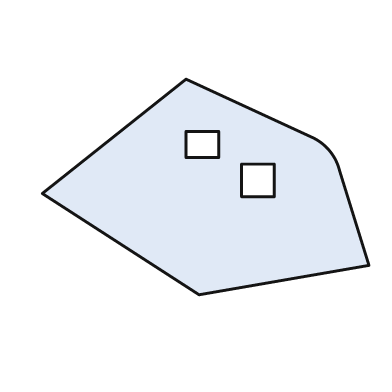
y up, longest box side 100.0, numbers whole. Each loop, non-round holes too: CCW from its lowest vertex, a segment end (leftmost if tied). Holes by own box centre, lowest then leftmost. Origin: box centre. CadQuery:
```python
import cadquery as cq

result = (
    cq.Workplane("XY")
    .moveTo(-2.0, -33.0)
    .lineTo(50.0, -24.0)
    .lineTo(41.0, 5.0)
    .threePointArc((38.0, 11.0), (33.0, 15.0))
    .lineTo(-6.0, 33.0)
    .lineTo(-50.0, -2.0)
    .close()
    .moveTo(11.0, -3.0)
    .lineTo(21.0, -3.0)
    .lineTo(21.0, 7.0)
    .lineTo(11.0, 7.0)
    .close()
    .moveTo(-6.0, 9.0)
    .lineTo(4.0, 9.0)
    .lineTo(4.0, 17.0)
    .lineTo(-6.0, 17.0)
    .close()
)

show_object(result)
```